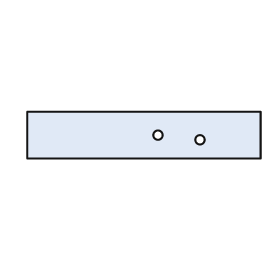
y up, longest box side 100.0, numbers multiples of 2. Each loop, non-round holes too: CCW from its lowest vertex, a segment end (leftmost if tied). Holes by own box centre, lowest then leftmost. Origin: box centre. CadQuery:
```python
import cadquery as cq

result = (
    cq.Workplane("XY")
    .moveTo(-50.0, -10.0)
    .lineTo(50.0, -10.0)
    .lineTo(50.0, 10.0)
    .lineTo(-50.0, 10.0)
    .close()
    .moveTo(24.0, -2.0)
    .circle(2.0)
    .moveTo(6.0, 0.0)
    .circle(2.0)
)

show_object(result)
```